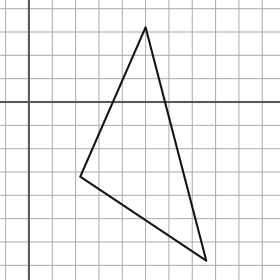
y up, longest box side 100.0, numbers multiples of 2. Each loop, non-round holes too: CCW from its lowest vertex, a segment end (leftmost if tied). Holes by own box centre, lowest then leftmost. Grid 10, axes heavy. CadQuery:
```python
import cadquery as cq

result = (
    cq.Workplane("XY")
    .moveTo(76.0, -68.0)
    .lineTo(50.0, 32.0)
    .lineTo(22.0, -32.0)
    .close()
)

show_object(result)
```